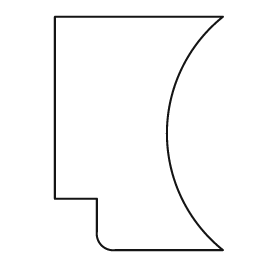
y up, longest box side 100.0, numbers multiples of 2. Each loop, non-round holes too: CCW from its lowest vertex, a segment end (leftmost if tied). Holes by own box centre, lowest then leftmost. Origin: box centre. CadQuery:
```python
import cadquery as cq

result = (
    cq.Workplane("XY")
    .moveTo(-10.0, -50.0)
    .lineTo(36.0, -50.0)
    .threePointArc((12.0, 0.0), (36.0, 50.0))
    .lineTo(-36.0, 50.0)
    .lineTo(-36.0, -28.0)
    .lineTo(-18.0, -28.0)
    .lineTo(-18.0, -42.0)
    .threePointArc((-16.0, -48.0), (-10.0, -50.0))
    .close()
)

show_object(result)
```